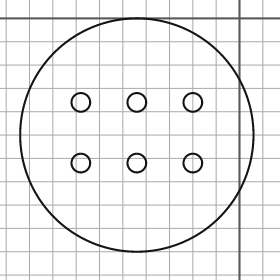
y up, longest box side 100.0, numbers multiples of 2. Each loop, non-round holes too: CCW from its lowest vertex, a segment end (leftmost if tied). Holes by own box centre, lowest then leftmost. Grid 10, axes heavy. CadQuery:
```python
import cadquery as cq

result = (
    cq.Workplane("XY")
    .moveTo(-44.0, -50.0)
    .circle(50.0)
    .moveTo(-68.0, -62.0)
    .circle(4.0)
    .moveTo(-44.0, -62.0)
    .circle(4.0)
    .moveTo(-20.0, -62.0)
    .circle(4.0)
    .moveTo(-68.0, -36.0)
    .circle(4.0)
    .moveTo(-44.0, -36.0)
    .circle(4.0)
    .moveTo(-20.0, -36.0)
    .circle(4.0)
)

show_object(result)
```